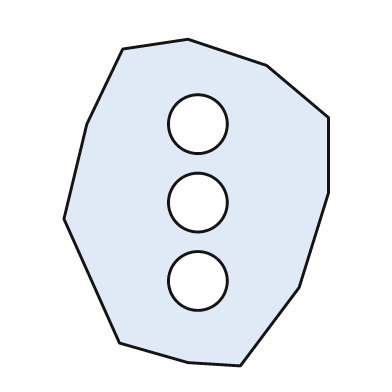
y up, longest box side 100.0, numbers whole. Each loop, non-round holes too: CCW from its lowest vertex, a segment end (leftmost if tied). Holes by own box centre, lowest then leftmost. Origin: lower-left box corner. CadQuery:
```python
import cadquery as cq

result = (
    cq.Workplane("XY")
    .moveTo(54.0, 0.0)
    .lineTo(72.0, 24.0)
    .lineTo(81.0, 53.0)
    .lineTo(81.0, 76.0)
    .lineTo(62.0, 92.0)
    .lineTo(38.0, 100.0)
    .lineTo(18.0, 97.0)
    .lineTo(7.0, 74.0)
    .lineTo(0.0, 45.0)
    .lineTo(17.0, 7.0)
    .lineTo(38.0, 1.0)
    .close()
    .moveTo(41.0, 26.0)
    .circle(9.0)
    .moveTo(41.0, 50.0)
    .circle(9.0)
    .moveTo(41.0, 74.0)
    .circle(9.0)
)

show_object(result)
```